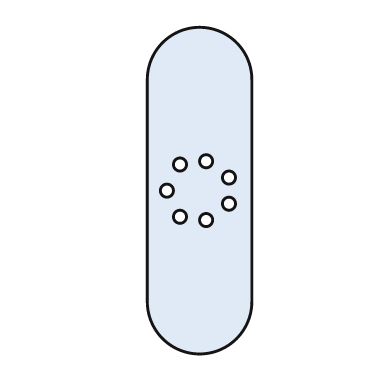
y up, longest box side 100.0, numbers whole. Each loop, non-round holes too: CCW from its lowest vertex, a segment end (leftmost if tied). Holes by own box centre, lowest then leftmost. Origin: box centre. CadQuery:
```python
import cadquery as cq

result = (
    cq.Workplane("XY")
    .moveTo(-16.0, -34.0)
    .threePointArc((0.0, -50.0), (16.0, -34.0))
    .lineTo(16.0, 34.0)
    .threePointArc((0.0, 50.0), (-16.0, 34.0))
    .close()
    .moveTo(2.0, -9.0)
    .circle(2.0)
    .moveTo(-6.0, -8.0)
    .circle(2.0)
    .moveTo(9.0, -4.0)
    .circle(2.0)
    .moveTo(-10.0, 0.0)
    .circle(2.0)
    .moveTo(9.0, 4.0)
    .circle(2.0)
    .moveTo(-6.0, 8.0)
    .circle(2.0)
    .moveTo(2.0, 9.0)
    .circle(2.0)
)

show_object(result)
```